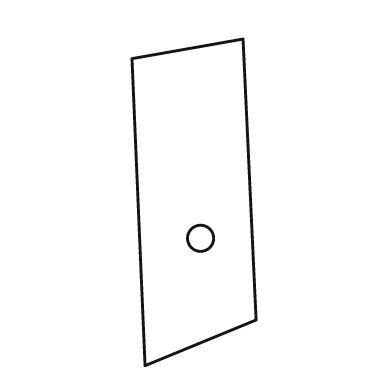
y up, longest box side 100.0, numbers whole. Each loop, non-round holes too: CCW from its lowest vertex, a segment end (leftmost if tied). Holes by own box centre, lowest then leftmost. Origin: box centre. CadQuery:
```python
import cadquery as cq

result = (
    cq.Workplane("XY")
    .moveTo(-15.0, -50.0)
    .lineTo(19.0, -36.0)
    .lineTo(15.0, 50.0)
    .lineTo(-19.0, 44.0)
    .close()
    .moveTo(2.0, -11.0)
    .circle(4.0)
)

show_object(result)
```